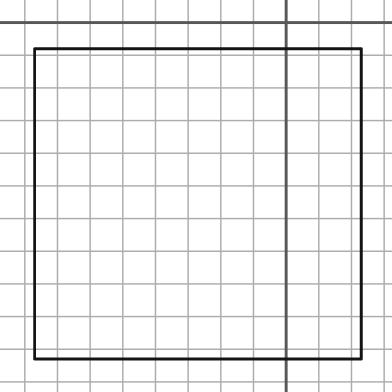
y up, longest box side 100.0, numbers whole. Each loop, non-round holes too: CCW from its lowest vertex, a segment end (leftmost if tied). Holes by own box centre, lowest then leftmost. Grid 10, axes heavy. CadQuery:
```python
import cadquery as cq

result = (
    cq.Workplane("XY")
    .moveTo(-77.0, -103.0)
    .lineTo(23.0, -103.0)
    .lineTo(23.0, -8.0)
    .lineTo(-77.0, -8.0)
    .close()
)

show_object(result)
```